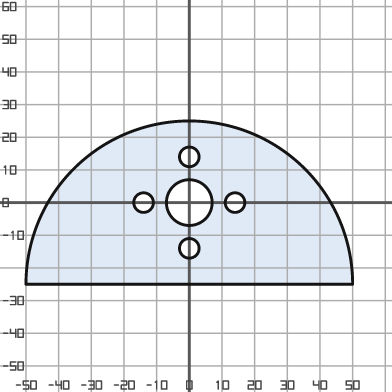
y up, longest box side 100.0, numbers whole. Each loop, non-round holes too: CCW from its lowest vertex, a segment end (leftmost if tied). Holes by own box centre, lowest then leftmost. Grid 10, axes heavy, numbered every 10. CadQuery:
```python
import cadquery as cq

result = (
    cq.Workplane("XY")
    .moveTo(-50.0, -25.0)
    .lineTo(50.0, -25.0)
    .threePointArc((0.0, 25.0), (-50.0, -25.0))
    .close()
    .moveTo(0.0, -14.0)
    .circle(3.0)
    .moveTo(-14.0, 0.0)
    .circle(3.0)
    .moveTo(0.0, 0.0)
    .circle(7.0)
    .moveTo(14.0, 0.0)
    .circle(3.0)
    .moveTo(0.0, 14.0)
    .circle(3.0)
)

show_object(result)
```